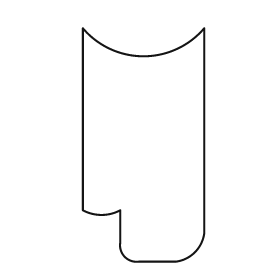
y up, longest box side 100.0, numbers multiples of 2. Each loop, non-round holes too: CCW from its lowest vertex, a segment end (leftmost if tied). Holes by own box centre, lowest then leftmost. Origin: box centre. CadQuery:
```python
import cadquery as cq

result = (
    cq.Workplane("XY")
    .moveTo(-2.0, -50.0)
    .lineTo(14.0, -50.0)
    .threePointArc((22.0, -46.0), (26.0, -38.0))
    .lineTo(26.0, 50.0)
    .threePointArc((0.0, 38.0), (-26.0, 50.0))
    .lineTo(-26.0, -28.0)
    .threePointArc((-18.0, -30.0), (-10.0, -28.0))
    .lineTo(-10.0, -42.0)
    .threePointArc((-8.0, -48.0), (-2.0, -50.0))
    .close()
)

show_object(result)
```